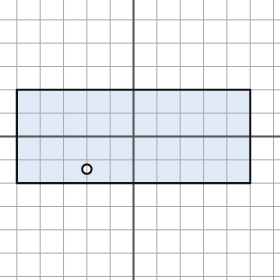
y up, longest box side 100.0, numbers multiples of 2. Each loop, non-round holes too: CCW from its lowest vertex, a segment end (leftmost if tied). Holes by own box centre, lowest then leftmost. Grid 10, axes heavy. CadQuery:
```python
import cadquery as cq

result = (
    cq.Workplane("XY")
    .moveTo(-50.0, -20.0)
    .lineTo(50.0, -20.0)
    .lineTo(50.0, 20.0)
    .lineTo(-50.0, 20.0)
    .close()
    .moveTo(-20.0, -14.0)
    .circle(2.0)
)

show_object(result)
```